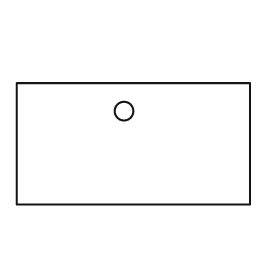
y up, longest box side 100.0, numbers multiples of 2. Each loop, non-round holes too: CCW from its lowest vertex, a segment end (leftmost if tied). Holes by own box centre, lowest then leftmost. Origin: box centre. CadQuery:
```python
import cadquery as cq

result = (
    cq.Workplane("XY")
    .moveTo(-50.0, -26.0)
    .lineTo(50.0, -26.0)
    .lineTo(50.0, 26.0)
    .lineTo(-50.0, 26.0)
    .close()
    .moveTo(-4.0, 14.0)
    .circle(4.0)
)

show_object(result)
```